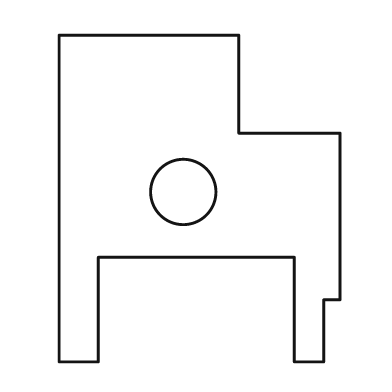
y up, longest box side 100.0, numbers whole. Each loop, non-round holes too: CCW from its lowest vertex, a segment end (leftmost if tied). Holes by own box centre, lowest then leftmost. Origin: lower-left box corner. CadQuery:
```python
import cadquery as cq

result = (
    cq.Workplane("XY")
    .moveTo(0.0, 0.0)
    .lineTo(12.0, 0.0)
    .lineTo(12.0, 32.0)
    .lineTo(72.0, 32.0)
    .lineTo(72.0, 0.0)
    .lineTo(81.0, 0.0)
    .lineTo(81.0, 19.0)
    .lineTo(86.0, 19.0)
    .lineTo(86.0, 70.0)
    .lineTo(55.0, 70.0)
    .lineTo(55.0, 100.0)
    .lineTo(0.0, 100.0)
    .close()
    .moveTo(38.0, 52.0)
    .circle(10.0)
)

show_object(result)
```